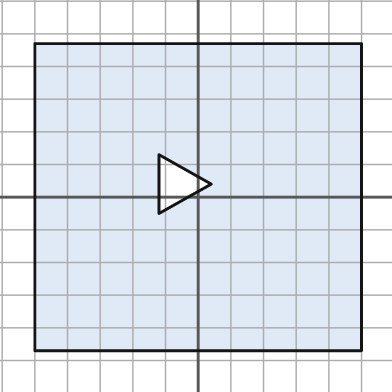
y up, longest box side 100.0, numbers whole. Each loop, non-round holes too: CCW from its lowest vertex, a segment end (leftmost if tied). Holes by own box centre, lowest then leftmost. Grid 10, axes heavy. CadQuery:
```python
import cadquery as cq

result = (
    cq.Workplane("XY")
    .moveTo(-50.0, -47.0)
    .lineTo(50.0, -47.0)
    .lineTo(50.0, 47.0)
    .lineTo(-50.0, 47.0)
    .close()
    .moveTo(-12.0, -5.0)
    .lineTo(4.0, 4.0)
    .lineTo(-12.0, 13.0)
    .close()
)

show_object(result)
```